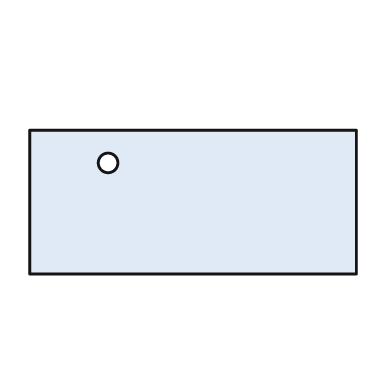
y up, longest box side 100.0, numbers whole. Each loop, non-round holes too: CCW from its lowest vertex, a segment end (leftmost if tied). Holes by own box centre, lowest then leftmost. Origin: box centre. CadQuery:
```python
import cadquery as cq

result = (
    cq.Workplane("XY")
    .moveTo(-50.0, -22.0)
    .lineTo(50.0, -22.0)
    .lineTo(50.0, 22.0)
    .lineTo(-50.0, 22.0)
    .close()
    .moveTo(-26.0, 12.0)
    .circle(3.0)
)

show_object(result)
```